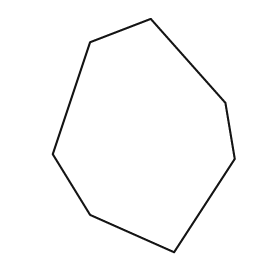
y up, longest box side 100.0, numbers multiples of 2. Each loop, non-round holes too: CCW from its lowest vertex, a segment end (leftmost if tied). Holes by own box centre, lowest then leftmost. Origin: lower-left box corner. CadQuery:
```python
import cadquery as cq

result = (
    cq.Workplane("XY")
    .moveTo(52.0, 0.0)
    .lineTo(78.0, 40.0)
    .lineTo(74.0, 64.0)
    .lineTo(42.0, 100.0)
    .lineTo(16.0, 90.0)
    .lineTo(0.0, 42.0)
    .lineTo(16.0, 16.0)
    .close()
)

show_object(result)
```